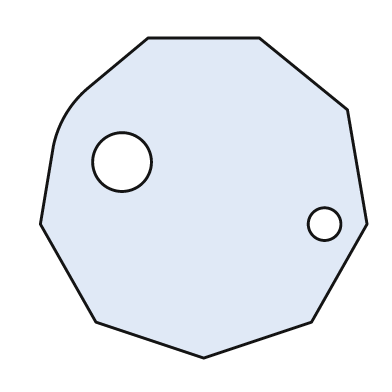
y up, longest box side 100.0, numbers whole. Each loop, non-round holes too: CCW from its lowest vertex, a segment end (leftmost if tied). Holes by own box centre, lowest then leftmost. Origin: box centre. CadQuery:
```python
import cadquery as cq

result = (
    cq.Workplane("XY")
    .moveTo(0.0, -49.0)
    .lineTo(33.0, -38.0)
    .lineTo(50.0, -8.0)
    .lineTo(44.0, 27.0)
    .lineTo(17.0, 49.0)
    .lineTo(-17.0, 49.0)
    .lineTo(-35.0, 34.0)
    .threePointArc((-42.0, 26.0), (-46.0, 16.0))
    .lineTo(-50.0, -8.0)
    .lineTo(-33.0, -38.0)
    .close()
    .moveTo(37.0, -8.0)
    .circle(5.0)
    .moveTo(-25.0, 11.0)
    .circle(9.0)
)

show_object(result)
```